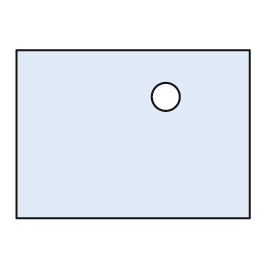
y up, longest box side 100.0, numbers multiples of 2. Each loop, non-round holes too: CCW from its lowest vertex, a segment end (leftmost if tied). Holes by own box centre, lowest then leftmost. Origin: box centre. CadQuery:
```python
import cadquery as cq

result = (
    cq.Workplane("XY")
    .moveTo(-50.0, -36.0)
    .lineTo(50.0, -36.0)
    .lineTo(50.0, 36.0)
    .lineTo(-50.0, 36.0)
    .close()
    .moveTo(14.0, 16.0)
    .circle(6.0)
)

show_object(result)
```